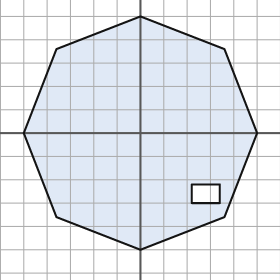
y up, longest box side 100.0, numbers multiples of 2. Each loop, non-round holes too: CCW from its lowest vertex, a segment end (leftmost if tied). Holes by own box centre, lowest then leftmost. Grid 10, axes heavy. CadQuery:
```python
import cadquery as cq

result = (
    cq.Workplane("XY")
    .moveTo(0.0, -50.0)
    .lineTo(36.0, -36.0)
    .lineTo(50.0, 0.0)
    .lineTo(36.0, 36.0)
    .lineTo(0.0, 50.0)
    .lineTo(-36.0, 36.0)
    .lineTo(-50.0, 0.0)
    .lineTo(-36.0, -36.0)
    .close()
    .moveTo(22.0, -30.0)
    .lineTo(34.0, -30.0)
    .lineTo(34.0, -22.0)
    .lineTo(22.0, -22.0)
    .close()
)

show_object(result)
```